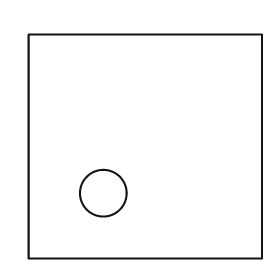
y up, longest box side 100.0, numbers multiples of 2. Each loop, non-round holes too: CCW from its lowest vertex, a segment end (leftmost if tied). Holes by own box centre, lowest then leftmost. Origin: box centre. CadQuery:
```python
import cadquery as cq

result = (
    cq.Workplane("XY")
    .moveTo(-50.0, -48.0)
    .lineTo(50.0, -48.0)
    .lineTo(50.0, 48.0)
    .lineTo(-50.0, 48.0)
    .close()
    .moveTo(-18.0, -20.0)
    .circle(10.0)
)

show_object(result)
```